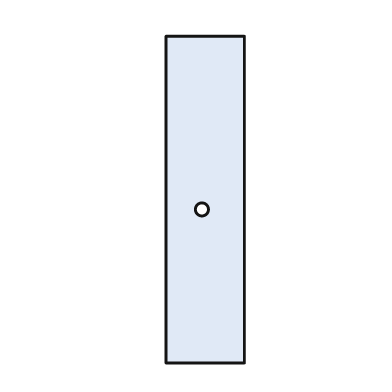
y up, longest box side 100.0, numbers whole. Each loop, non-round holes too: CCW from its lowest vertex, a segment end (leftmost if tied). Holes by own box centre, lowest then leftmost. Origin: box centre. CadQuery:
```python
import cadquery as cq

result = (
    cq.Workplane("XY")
    .moveTo(-12.0, -50.0)
    .lineTo(12.0, -50.0)
    .lineTo(12.0, 50.0)
    .lineTo(-12.0, 50.0)
    .close()
    .moveTo(-1.0, -3.0)
    .circle(2.0)
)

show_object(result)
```